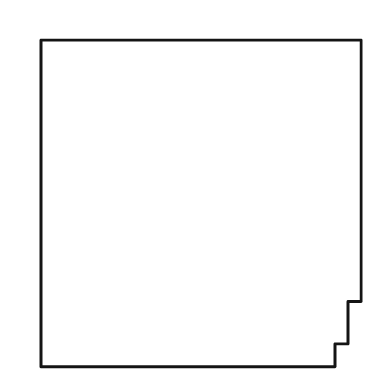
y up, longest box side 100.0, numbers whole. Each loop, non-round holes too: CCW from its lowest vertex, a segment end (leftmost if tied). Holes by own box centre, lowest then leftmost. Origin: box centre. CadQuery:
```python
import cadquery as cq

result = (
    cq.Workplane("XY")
    .moveTo(-49.0, -50.0)
    .lineTo(41.0, -50.0)
    .lineTo(41.0, -43.0)
    .lineTo(45.0, -43.0)
    .lineTo(45.0, -30.0)
    .lineTo(49.0, -30.0)
    .lineTo(49.0, 50.0)
    .lineTo(-49.0, 50.0)
    .close()
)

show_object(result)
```